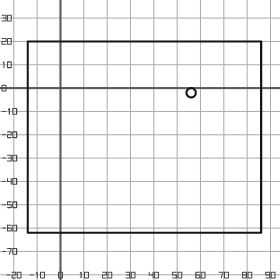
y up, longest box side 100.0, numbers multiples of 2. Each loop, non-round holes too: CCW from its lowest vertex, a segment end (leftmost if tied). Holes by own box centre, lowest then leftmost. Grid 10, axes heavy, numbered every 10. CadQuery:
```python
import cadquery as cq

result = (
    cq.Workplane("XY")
    .moveTo(-14.0, -62.0)
    .lineTo(86.0, -62.0)
    .lineTo(86.0, 20.0)
    .lineTo(-14.0, 20.0)
    .close()
    .moveTo(56.0, -2.0)
    .circle(2.0)
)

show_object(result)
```